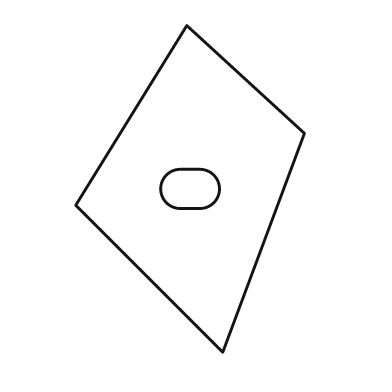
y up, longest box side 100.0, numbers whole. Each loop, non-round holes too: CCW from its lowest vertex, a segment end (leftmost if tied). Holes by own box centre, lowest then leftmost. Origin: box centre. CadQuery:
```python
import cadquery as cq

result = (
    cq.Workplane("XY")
    .moveTo(10.0, -50.0)
    .lineTo(35.0, 17.0)
    .lineTo(-1.0, 50.0)
    .lineTo(-35.0, -5.0)
    .close()
    .moveTo(-3.0, -6.0)
    .lineTo(3.0, -6.0)
    .threePointArc((9.0, 0.0), (3.0, 6.0))
    .lineTo(-3.0, 6.0)
    .threePointArc((-9.0, 0.0), (-3.0, -6.0))
    .close()
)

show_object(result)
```